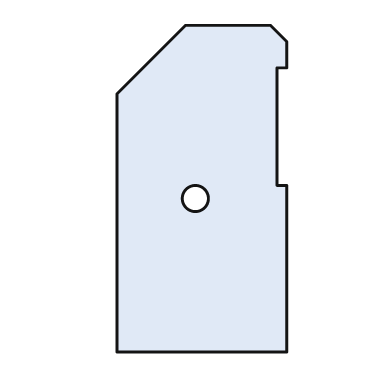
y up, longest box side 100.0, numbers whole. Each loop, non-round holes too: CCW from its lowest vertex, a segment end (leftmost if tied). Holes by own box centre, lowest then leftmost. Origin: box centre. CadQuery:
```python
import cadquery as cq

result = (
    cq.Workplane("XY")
    .moveTo(-26.0, -50.0)
    .lineTo(26.0, -50.0)
    .lineTo(26.0, 1.0)
    .lineTo(23.0, 1.0)
    .lineTo(23.0, 37.0)
    .lineTo(26.0, 37.0)
    .lineTo(26.0, 45.0)
    .lineTo(21.0, 50.0)
    .lineTo(-5.0, 50.0)
    .lineTo(-26.0, 29.0)
    .close()
    .moveTo(-2.0, -3.0)
    .circle(4.0)
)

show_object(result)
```